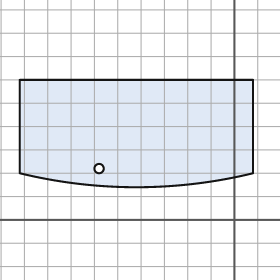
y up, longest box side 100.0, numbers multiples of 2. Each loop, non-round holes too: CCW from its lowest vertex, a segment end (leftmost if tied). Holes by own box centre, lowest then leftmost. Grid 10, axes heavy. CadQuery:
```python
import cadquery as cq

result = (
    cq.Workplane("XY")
    .moveTo(-92.0, 20.0)
    .threePointArc((-42.0, 14.0), (8.0, 20.0))
    .lineTo(8.0, 60.0)
    .lineTo(-92.0, 60.0)
    .close()
    .moveTo(-58.0, 22.0)
    .circle(2.0)
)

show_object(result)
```